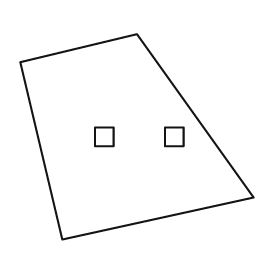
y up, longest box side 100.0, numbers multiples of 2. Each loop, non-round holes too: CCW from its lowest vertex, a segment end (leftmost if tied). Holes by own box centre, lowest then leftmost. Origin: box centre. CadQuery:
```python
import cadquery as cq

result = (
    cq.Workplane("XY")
    .moveTo(-32.0, -44.0)
    .lineTo(50.0, -26.0)
    .lineTo(0.0, 44.0)
    .lineTo(-50.0, 32.0)
    .close()
    .moveTo(-18.0, -4.0)
    .lineTo(-10.0, -4.0)
    .lineTo(-10.0, 4.0)
    .lineTo(-18.0, 4.0)
    .close()
    .moveTo(12.0, -4.0)
    .lineTo(20.0, -4.0)
    .lineTo(20.0, 4.0)
    .lineTo(12.0, 4.0)
    .close()
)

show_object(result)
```